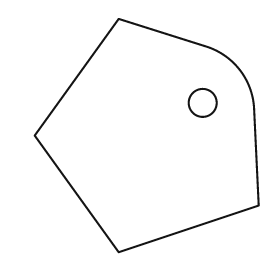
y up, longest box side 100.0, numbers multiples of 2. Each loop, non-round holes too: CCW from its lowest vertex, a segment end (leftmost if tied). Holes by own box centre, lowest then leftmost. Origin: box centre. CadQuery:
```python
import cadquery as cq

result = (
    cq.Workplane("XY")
    .moveTo(-12.0, -50.0)
    .lineTo(48.0, -30.0)
    .lineTo(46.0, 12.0)
    .threePointArc((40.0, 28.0), (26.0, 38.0))
    .lineTo(-12.0, 50.0)
    .lineTo(-48.0, 0.0)
    .close()
    .moveTo(24.0, 14.0)
    .circle(6.0)
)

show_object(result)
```